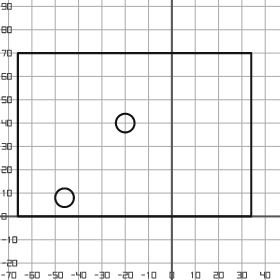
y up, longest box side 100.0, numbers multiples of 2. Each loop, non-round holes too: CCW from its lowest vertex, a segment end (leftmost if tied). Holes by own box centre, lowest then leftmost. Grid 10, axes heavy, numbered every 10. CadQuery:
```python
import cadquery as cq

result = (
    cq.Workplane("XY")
    .moveTo(-66.0, 0.0)
    .lineTo(34.0, 0.0)
    .lineTo(34.0, 70.0)
    .lineTo(-66.0, 70.0)
    .close()
    .moveTo(-46.0, 8.0)
    .circle(4.0)
    .moveTo(-20.0, 40.0)
    .circle(4.0)
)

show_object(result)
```